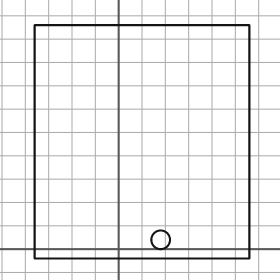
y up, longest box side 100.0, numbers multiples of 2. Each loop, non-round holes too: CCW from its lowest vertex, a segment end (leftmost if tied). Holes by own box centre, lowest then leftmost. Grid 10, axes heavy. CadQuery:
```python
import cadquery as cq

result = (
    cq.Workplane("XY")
    .moveTo(-36.0, -4.0)
    .lineTo(56.0, -4.0)
    .lineTo(56.0, 96.0)
    .lineTo(-36.0, 96.0)
    .close()
    .moveTo(18.0, 4.0)
    .circle(4.0)
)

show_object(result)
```